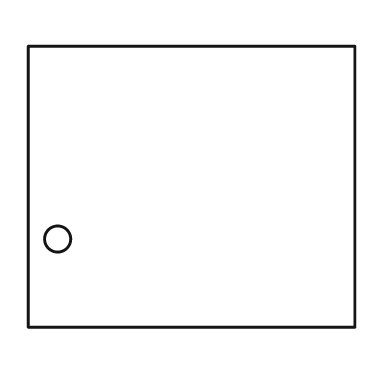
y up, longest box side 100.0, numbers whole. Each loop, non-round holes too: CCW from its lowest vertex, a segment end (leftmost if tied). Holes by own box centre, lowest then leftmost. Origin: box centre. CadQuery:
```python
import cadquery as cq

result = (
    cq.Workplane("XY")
    .moveTo(-50.0, -43.0)
    .lineTo(50.0, -43.0)
    .lineTo(50.0, 43.0)
    .lineTo(-50.0, 43.0)
    .close()
    .moveTo(-41.0, -16.0)
    .circle(4.0)
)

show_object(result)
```